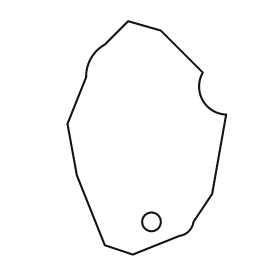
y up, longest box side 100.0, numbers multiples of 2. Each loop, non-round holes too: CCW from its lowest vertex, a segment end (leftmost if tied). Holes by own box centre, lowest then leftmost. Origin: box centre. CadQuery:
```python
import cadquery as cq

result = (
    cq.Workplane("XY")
    .moveTo(-6.0, -50.0)
    .lineTo(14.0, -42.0)
    .threePointArc((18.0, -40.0), (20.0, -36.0))
    .lineTo(28.0, -24.0)
    .lineTo(34.0, 10.0)
    .threePointArc((24.0, 16.0), (24.0, 28.0))
    .lineTo(6.0, 46.0)
    .lineTo(-8.0, 50.0)
    .lineTo(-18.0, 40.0)
    .threePointArc((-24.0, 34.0), (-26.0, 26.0))
    .lineTo(-34.0, 6.0)
    .lineTo(-30.0, -16.0)
    .lineTo(-18.0, -46.0)
    .close()
    .moveTo(2.0, -36.0)
    .circle(4.0)
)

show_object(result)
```